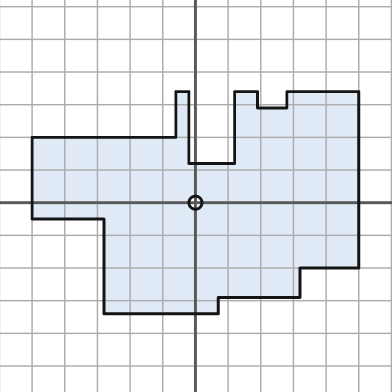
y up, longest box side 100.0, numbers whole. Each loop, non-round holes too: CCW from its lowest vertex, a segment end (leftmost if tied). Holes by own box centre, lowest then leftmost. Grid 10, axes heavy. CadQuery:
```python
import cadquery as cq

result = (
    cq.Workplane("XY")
    .moveTo(-28.0, -34.0)
    .lineTo(7.0, -34.0)
    .lineTo(7.0, -29.0)
    .lineTo(32.0, -29.0)
    .lineTo(32.0, -20.0)
    .lineTo(50.0, -20.0)
    .lineTo(50.0, 34.0)
    .lineTo(28.0, 34.0)
    .lineTo(28.0, 29.0)
    .lineTo(19.0, 29.0)
    .lineTo(19.0, 34.0)
    .lineTo(12.0, 34.0)
    .lineTo(12.0, 12.0)
    .lineTo(-2.0, 12.0)
    .lineTo(-2.0, 34.0)
    .lineTo(-6.0, 34.0)
    .lineTo(-6.0, 20.0)
    .lineTo(-50.0, 20.0)
    .lineTo(-50.0, -5.0)
    .lineTo(-28.0, -5.0)
    .close()
    .moveTo(0.0, 0.0)
    .circle(2.0)
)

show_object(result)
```